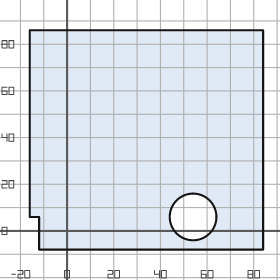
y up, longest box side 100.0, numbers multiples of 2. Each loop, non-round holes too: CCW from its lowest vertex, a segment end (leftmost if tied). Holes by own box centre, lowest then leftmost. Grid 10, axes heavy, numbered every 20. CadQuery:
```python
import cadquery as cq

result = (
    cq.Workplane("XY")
    .moveTo(-12.0, -8.0)
    .lineTo(84.0, -8.0)
    .lineTo(84.0, 86.0)
    .lineTo(-16.0, 86.0)
    .lineTo(-16.0, 6.0)
    .lineTo(-12.0, 6.0)
    .close()
    .moveTo(54.0, 6.0)
    .circle(10.0)
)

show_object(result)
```